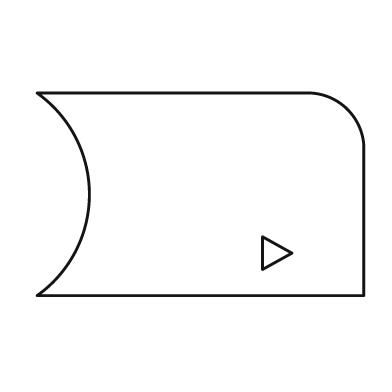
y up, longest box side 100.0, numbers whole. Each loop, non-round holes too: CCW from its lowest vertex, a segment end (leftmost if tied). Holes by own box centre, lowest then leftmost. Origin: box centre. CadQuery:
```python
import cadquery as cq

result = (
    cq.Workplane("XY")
    .moveTo(-50.0, -31.0)
    .lineTo(50.0, -31.0)
    .lineTo(50.0, 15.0)
    .threePointArc((45.0, 26.0), (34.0, 31.0))
    .lineTo(-50.0, 31.0)
    .threePointArc((-34.0, 0.0), (-50.0, -31.0))
    .close()
    .moveTo(19.0, -23.0)
    .lineTo(28.0, -18.0)
    .lineTo(19.0, -13.0)
    .close()
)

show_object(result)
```